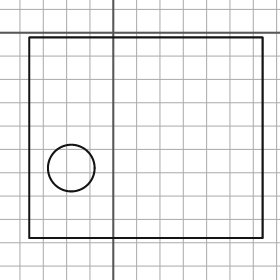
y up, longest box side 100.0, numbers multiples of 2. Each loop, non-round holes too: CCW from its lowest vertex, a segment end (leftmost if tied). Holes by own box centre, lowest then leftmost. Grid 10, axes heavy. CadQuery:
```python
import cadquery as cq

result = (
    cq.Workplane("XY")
    .moveTo(-36.0, -88.0)
    .lineTo(64.0, -88.0)
    .lineTo(64.0, -2.0)
    .lineTo(-36.0, -2.0)
    .close()
    .moveTo(-18.0, -58.0)
    .circle(10.0)
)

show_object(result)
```